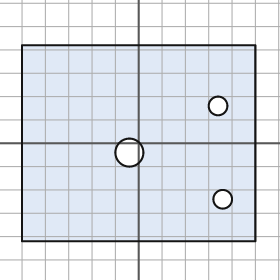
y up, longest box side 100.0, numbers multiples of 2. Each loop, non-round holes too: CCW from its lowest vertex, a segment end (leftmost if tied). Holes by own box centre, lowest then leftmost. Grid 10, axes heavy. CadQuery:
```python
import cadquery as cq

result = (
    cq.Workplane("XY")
    .moveTo(-50.0, -42.0)
    .lineTo(50.0, -42.0)
    .lineTo(50.0, 42.0)
    .lineTo(-50.0, 42.0)
    .close()
    .moveTo(36.0, -24.0)
    .circle(4.0)
    .moveTo(-4.0, -4.0)
    .circle(6.0)
    .moveTo(34.0, 16.0)
    .circle(4.0)
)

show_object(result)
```